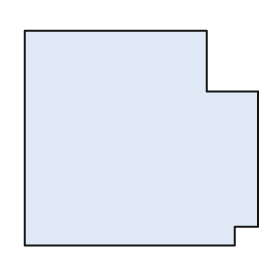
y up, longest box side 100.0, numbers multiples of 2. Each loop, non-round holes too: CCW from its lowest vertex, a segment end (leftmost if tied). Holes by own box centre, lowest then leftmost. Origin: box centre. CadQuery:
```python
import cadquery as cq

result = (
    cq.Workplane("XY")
    .moveTo(-50.0, -46.0)
    .lineTo(40.0, -46.0)
    .lineTo(40.0, -38.0)
    .lineTo(50.0, -38.0)
    .lineTo(50.0, 20.0)
    .lineTo(28.0, 20.0)
    .lineTo(28.0, 46.0)
    .lineTo(-50.0, 46.0)
    .close()
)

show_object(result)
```